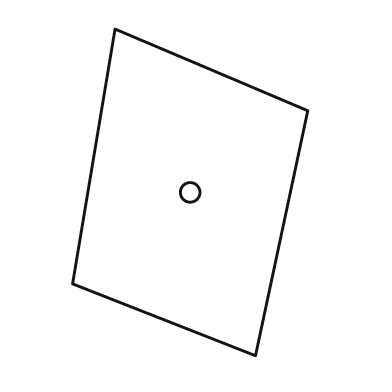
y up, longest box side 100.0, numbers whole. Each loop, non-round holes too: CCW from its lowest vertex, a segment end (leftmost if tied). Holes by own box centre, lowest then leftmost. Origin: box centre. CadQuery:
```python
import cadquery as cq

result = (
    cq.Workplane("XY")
    .moveTo(20.0, -50.0)
    .lineTo(36.0, 25.0)
    .lineTo(-23.0, 50.0)
    .lineTo(-36.0, -28.0)
    .close()
    .moveTo(0.0, 0.0)
    .circle(3.0)
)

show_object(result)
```